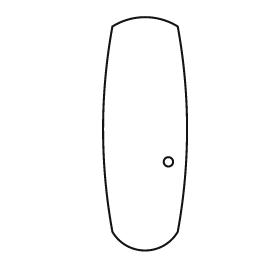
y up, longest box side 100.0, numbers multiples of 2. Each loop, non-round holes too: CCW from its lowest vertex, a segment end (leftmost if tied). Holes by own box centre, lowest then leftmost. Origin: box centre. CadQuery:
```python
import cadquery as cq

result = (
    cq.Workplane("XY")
    .moveTo(-14.0, -42.0)
    .threePointArc((0.0, -50.0), (14.0, -42.0))
    .threePointArc((18.0, 2.0), (14.0, 46.0))
    .threePointArc((0.0, 50.0), (-14.0, 46.0))
    .threePointArc((-18.0, 2.0), (-14.0, -42.0))
    .close()
    .moveTo(10.0, -12.0)
    .circle(2.0)
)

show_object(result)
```